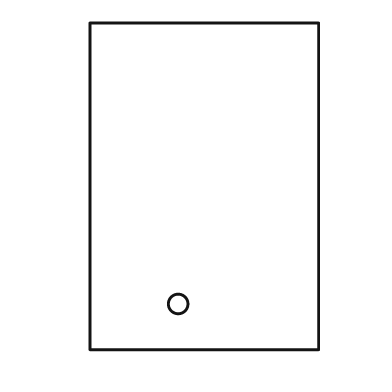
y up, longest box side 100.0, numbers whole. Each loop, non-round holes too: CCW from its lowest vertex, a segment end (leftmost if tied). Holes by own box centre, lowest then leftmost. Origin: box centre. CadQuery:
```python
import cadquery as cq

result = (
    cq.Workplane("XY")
    .moveTo(-35.0, -50.0)
    .lineTo(35.0, -50.0)
    .lineTo(35.0, 50.0)
    .lineTo(-35.0, 50.0)
    .close()
    .moveTo(-8.0, -36.0)
    .circle(3.0)
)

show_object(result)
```